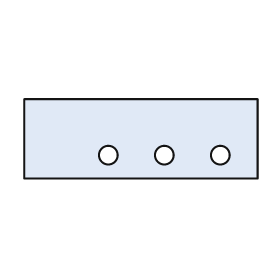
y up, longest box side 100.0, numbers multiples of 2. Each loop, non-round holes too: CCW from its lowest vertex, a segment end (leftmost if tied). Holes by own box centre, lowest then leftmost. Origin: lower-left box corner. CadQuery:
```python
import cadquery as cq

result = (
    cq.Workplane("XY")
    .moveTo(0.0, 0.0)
    .lineTo(100.0, 0.0)
    .lineTo(100.0, 34.0)
    .lineTo(0.0, 34.0)
    .close()
    .moveTo(36.0, 10.0)
    .circle(4.0)
    .moveTo(60.0, 10.0)
    .circle(4.0)
    .moveTo(84.0, 10.0)
    .circle(4.0)
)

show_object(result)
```